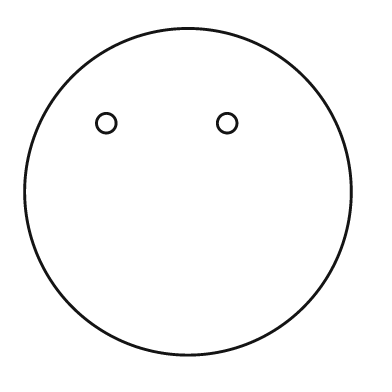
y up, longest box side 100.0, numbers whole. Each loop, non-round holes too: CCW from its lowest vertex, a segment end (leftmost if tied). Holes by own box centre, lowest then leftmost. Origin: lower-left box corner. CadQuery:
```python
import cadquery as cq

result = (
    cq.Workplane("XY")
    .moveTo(50.0, 50.0)
    .circle(50.0)
    .moveTo(25.0, 71.0)
    .circle(3.0)
    .moveTo(62.0, 71.0)
    .circle(3.0)
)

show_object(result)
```